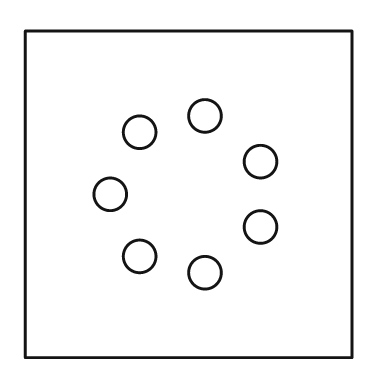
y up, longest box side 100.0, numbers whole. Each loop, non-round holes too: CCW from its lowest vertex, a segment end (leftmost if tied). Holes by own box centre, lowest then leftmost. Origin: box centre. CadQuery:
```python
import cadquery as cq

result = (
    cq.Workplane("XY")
    .moveTo(-50.0, -50.0)
    .lineTo(50.0, -50.0)
    .lineTo(50.0, 50.0)
    .lineTo(-50.0, 50.0)
    .close()
    .moveTo(5.0, -24.0)
    .circle(5.0)
    .moveTo(-15.0, -19.0)
    .circle(5.0)
    .moveTo(22.0, -10.0)
    .circle(5.0)
    .moveTo(-24.0, 0.0)
    .circle(5.0)
    .moveTo(22.0, 10.0)
    .circle(5.0)
    .moveTo(-15.0, 19.0)
    .circle(5.0)
    .moveTo(5.0, 24.0)
    .circle(5.0)
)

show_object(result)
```